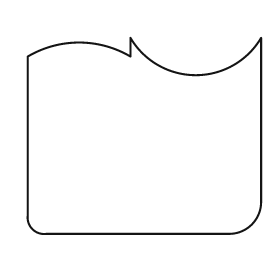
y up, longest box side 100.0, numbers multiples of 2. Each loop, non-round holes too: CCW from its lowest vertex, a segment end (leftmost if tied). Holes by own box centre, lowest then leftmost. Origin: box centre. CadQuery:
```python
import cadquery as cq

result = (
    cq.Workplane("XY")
    .moveTo(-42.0, -42.0)
    .lineTo(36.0, -42.0)
    .threePointArc((46.0, -38.0), (50.0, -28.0))
    .lineTo(50.0, 42.0)
    .threePointArc((22.0, 26.0), (-6.0, 42.0))
    .lineTo(-6.0, 34.0)
    .threePointArc((-28.0, 40.0), (-50.0, 34.0))
    .lineTo(-50.0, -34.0)
    .threePointArc((-48.0, -40.0), (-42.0, -42.0))
    .close()
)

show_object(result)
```